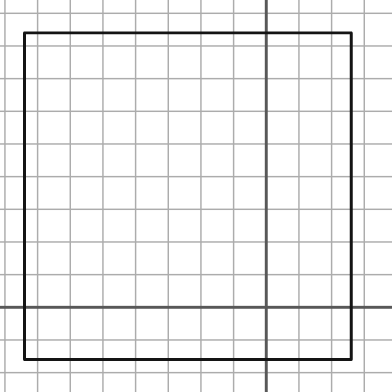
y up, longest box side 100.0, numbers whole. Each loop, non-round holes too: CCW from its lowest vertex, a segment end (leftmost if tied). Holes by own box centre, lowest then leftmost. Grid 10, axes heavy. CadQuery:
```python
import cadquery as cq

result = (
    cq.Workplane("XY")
    .moveTo(-74.0, -16.0)
    .lineTo(26.0, -16.0)
    .lineTo(26.0, 84.0)
    .lineTo(-74.0, 84.0)
    .close()
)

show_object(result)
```